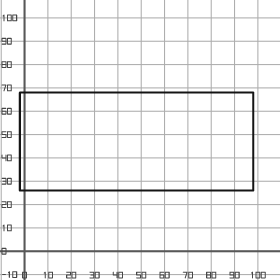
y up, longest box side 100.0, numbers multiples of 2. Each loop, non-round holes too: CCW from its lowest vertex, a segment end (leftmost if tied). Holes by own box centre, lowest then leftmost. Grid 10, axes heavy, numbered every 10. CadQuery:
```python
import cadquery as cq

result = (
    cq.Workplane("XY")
    .moveTo(-2.0, 26.0)
    .lineTo(98.0, 26.0)
    .lineTo(98.0, 68.0)
    .lineTo(-2.0, 68.0)
    .close()
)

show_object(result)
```